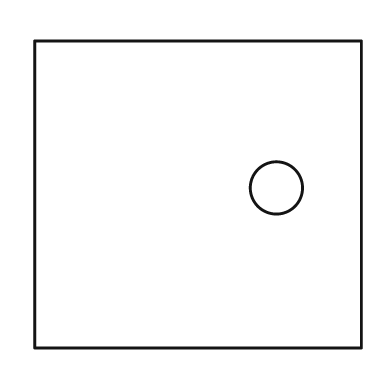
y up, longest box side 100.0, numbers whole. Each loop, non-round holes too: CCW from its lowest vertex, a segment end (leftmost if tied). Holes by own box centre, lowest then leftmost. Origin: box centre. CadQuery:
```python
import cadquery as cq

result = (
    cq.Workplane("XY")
    .moveTo(-50.0, -47.0)
    .lineTo(50.0, -47.0)
    .lineTo(50.0, 47.0)
    .lineTo(-50.0, 47.0)
    .close()
    .moveTo(24.0, 2.0)
    .circle(8.0)
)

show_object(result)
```